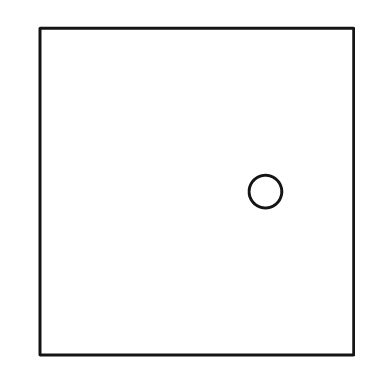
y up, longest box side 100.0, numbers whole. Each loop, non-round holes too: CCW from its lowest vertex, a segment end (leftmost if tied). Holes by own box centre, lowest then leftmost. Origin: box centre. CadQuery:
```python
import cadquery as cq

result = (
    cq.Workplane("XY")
    .moveTo(-48.0, -50.0)
    .lineTo(48.0, -50.0)
    .lineTo(48.0, 50.0)
    .lineTo(-48.0, 50.0)
    .close()
    .moveTo(21.0, 0.0)
    .circle(5.0)
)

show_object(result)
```